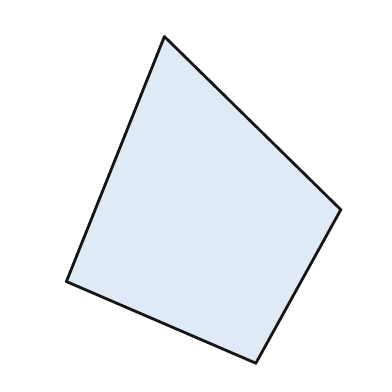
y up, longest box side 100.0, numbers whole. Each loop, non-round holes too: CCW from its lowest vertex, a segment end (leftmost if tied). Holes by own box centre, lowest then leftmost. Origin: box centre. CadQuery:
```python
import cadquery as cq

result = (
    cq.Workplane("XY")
    .moveTo(16.0, -50.0)
    .lineTo(42.0, -3.0)
    .lineTo(-12.0, 50.0)
    .lineTo(-42.0, -25.0)
    .close()
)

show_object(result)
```